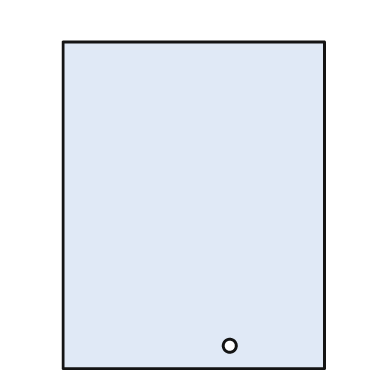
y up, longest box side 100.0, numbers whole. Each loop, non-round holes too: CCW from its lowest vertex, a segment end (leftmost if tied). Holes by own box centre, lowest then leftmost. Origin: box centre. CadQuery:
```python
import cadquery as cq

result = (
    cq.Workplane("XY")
    .moveTo(-40.0, -50.0)
    .lineTo(40.0, -50.0)
    .lineTo(40.0, 50.0)
    .lineTo(-40.0, 50.0)
    .close()
    .moveTo(11.0, -43.0)
    .circle(2.0)
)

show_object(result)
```